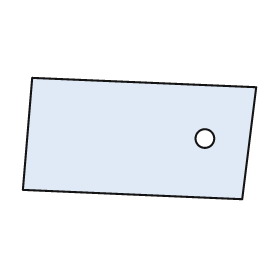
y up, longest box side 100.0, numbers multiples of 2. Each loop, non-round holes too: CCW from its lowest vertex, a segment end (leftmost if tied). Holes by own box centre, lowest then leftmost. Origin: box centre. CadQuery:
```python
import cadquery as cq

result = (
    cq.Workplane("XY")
    .moveTo(44.0, -26.0)
    .lineTo(50.0, 22.0)
    .lineTo(-46.0, 26.0)
    .lineTo(-50.0, -22.0)
    .close()
    .moveTo(28.0, 0.0)
    .circle(4.0)
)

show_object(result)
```